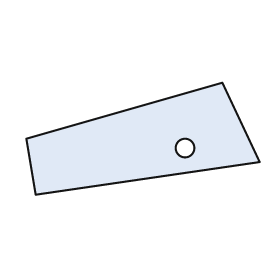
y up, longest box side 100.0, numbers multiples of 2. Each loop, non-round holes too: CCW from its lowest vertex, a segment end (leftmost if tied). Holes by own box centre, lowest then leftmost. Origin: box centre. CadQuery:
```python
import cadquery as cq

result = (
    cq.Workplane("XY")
    .moveTo(-46.0, -24.0)
    .lineTo(50.0, -10.0)
    .lineTo(34.0, 24.0)
    .lineTo(-50.0, 0.0)
    .close()
    .moveTo(18.0, -4.0)
    .circle(4.0)
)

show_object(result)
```